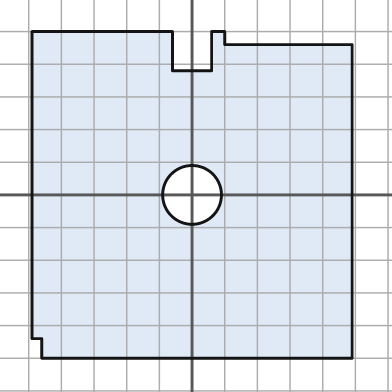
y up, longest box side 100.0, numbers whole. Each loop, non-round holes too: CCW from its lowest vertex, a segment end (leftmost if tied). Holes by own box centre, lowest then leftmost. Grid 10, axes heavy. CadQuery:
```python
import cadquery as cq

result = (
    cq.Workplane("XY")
    .moveTo(-46.0, -50.0)
    .lineTo(49.0, -50.0)
    .lineTo(49.0, 46.0)
    .lineTo(10.0, 46.0)
    .lineTo(10.0, 50.0)
    .lineTo(6.0, 50.0)
    .lineTo(6.0, 38.0)
    .lineTo(-6.0, 38.0)
    .lineTo(-6.0, 50.0)
    .lineTo(-49.0, 50.0)
    .lineTo(-49.0, -44.0)
    .lineTo(-46.0, -44.0)
    .close()
    .moveTo(0.0, 0.0)
    .circle(9.0)
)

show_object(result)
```